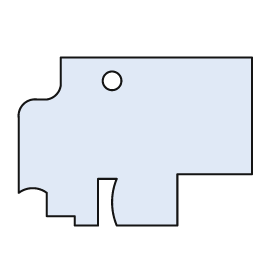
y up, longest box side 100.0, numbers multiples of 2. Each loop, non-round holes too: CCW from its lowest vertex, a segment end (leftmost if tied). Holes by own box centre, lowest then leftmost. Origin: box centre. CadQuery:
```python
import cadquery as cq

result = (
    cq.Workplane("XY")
    .moveTo(-26.0, -36.0)
    .lineTo(-16.0, -36.0)
    .lineTo(-16.0, -16.0)
    .lineTo(-8.0, -16.0)
    .threePointArc((-10.0, -26.0), (-8.0, -36.0))
    .lineTo(18.0, -36.0)
    .lineTo(18.0, -14.0)
    .lineTo(50.0, -14.0)
    .lineTo(50.0, 36.0)
    .lineTo(-32.0, 36.0)
    .lineTo(-32.0, 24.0)
    .threePointArc((-34.0, 20.0), (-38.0, 18.0))
    .lineTo(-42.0, 18.0)
    .threePointArc((-48.0, 16.0), (-50.0, 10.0))
    .lineTo(-50.0, -22.0)
    .threePointArc((-44.0, -20.0), (-38.0, -22.0))
    .lineTo(-38.0, -32.0)
    .lineTo(-26.0, -32.0)
    .close()
    .moveTo(-10.0, 26.0)
    .circle(4.0)
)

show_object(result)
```